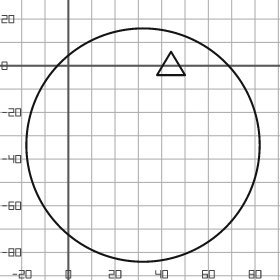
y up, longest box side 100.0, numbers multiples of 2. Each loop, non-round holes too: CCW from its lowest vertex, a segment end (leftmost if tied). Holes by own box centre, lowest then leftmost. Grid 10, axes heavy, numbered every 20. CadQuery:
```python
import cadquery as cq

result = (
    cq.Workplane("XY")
    .moveTo(32.0, -34.0)
    .circle(50.0)
    .moveTo(38.0, -4.0)
    .lineTo(50.0, -4.0)
    .lineTo(44.0, 6.0)
    .close()
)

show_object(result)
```